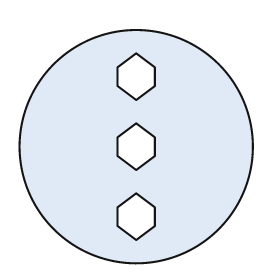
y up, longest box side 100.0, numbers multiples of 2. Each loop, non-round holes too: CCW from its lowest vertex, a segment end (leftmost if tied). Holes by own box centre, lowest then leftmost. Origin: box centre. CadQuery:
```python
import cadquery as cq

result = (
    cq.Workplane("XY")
    .moveTo(0.0, 0.0)
    .circle(50.0)
    .moveTo(0.0, -40.0)
    .lineTo(8.0, -34.0)
    .lineTo(8.0, -26.0)
    .lineTo(0.0, -20.0)
    .lineTo(-8.0, -26.0)
    .lineTo(-8.0, -34.0)
    .close()
    .moveTo(0.0, -10.0)
    .lineTo(8.0, -4.0)
    .lineTo(8.0, 4.0)
    .lineTo(0.0, 10.0)
    .lineTo(-8.0, 4.0)
    .lineTo(-8.0, -4.0)
    .close()
    .moveTo(0.0, 20.0)
    .lineTo(8.0, 26.0)
    .lineTo(8.0, 34.0)
    .lineTo(0.0, 40.0)
    .lineTo(-8.0, 34.0)
    .lineTo(-8.0, 26.0)
    .close()
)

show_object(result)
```